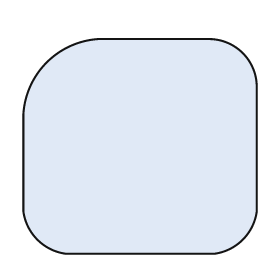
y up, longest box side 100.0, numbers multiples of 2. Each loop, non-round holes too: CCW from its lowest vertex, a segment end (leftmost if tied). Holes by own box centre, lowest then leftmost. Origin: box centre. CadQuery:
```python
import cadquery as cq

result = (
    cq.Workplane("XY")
    .moveTo(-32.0, -46.0)
    .lineTo(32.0, -46.0)
    .threePointArc((44.0, -40.0), (50.0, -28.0))
    .lineTo(50.0, 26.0)
    .threePointArc((44.0, 40.0), (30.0, 46.0))
    .lineTo(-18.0, 46.0)
    .threePointArc((-40.0, 36.0), (-50.0, 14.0))
    .lineTo(-50.0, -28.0)
    .threePointArc((-44.0, -40.0), (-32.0, -46.0))
    .close()
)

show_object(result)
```